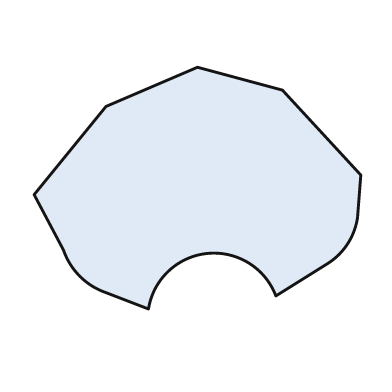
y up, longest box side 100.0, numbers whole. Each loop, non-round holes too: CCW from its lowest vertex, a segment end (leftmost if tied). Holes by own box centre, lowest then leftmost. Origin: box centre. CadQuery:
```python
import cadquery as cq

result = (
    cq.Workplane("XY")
    .moveTo(-15.0, -37.0)
    .threePointArc((3.0, -20.0), (24.0, -33.0))
    .lineTo(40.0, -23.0)
    .threePointArc((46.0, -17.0), (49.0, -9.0))
    .lineTo(50.0, 4.0)
    .lineTo(26.0, 30.0)
    .lineTo(0.0, 37.0)
    .lineTo(-28.0, 25.0)
    .lineTo(-50.0, -2.0)
    .lineTo(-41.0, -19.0)
    .threePointArc((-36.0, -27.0), (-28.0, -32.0))
    .close()
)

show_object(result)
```